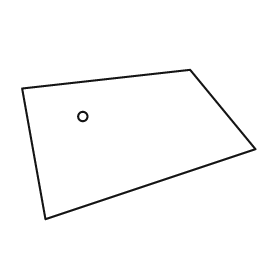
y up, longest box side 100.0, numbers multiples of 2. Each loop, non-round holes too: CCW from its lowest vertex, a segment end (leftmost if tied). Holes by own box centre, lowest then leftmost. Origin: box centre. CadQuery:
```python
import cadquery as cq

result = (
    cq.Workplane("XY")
    .moveTo(-40.0, -32.0)
    .lineTo(50.0, -2.0)
    .lineTo(22.0, 32.0)
    .lineTo(-50.0, 24.0)
    .close()
    .moveTo(-24.0, 12.0)
    .circle(2.0)
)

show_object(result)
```